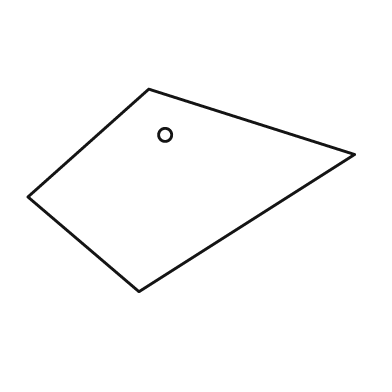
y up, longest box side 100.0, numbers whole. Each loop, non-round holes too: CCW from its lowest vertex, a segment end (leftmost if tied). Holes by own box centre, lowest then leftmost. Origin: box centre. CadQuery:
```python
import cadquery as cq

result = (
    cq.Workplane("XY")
    .moveTo(-16.0, -31.0)
    .lineTo(50.0, 11.0)
    .lineTo(-13.0, 31.0)
    .lineTo(-50.0, -2.0)
    .close()
    .moveTo(-8.0, 17.0)
    .circle(2.0)
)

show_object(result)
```